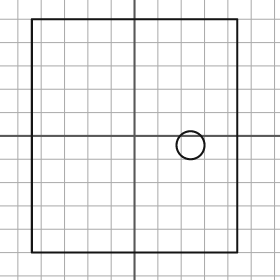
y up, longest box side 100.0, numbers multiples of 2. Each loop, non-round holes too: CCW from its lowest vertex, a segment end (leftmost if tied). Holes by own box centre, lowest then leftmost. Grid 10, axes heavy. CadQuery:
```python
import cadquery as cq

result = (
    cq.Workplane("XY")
    .moveTo(-44.0, -50.0)
    .lineTo(44.0, -50.0)
    .lineTo(44.0, 50.0)
    .lineTo(-44.0, 50.0)
    .close()
    .moveTo(24.0, -4.0)
    .circle(6.0)
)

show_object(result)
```